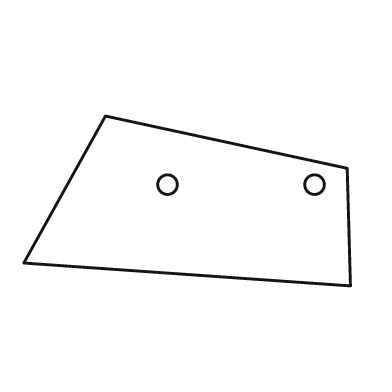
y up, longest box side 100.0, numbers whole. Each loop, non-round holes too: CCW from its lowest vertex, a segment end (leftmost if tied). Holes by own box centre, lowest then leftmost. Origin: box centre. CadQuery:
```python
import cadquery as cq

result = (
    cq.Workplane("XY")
    .moveTo(50.0, -26.0)
    .lineTo(49.0, 10.0)
    .lineTo(-25.0, 26.0)
    .lineTo(-50.0, -19.0)
    .close()
    .moveTo(-6.0, 5.0)
    .circle(3.0)
    .moveTo(39.0, 5.0)
    .circle(3.0)
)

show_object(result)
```